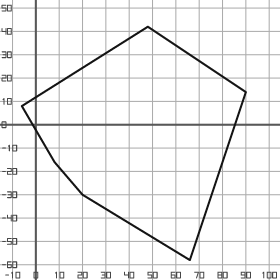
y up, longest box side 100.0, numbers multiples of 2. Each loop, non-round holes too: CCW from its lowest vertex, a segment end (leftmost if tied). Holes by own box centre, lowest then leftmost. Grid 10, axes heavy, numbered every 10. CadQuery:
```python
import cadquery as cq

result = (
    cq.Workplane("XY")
    .moveTo(66.0, -58.0)
    .lineTo(90.0, 14.0)
    .lineTo(48.0, 42.0)
    .lineTo(-6.0, 8.0)
    .lineTo(8.0, -16.0)
    .lineTo(20.0, -30.0)
    .close()
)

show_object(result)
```